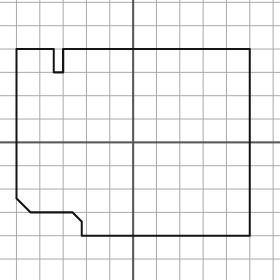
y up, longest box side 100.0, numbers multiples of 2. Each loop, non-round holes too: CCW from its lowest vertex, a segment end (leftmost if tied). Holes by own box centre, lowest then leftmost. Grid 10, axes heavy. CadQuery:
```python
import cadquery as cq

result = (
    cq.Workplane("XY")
    .moveTo(-22.0, -40.0)
    .lineTo(50.0, -40.0)
    .lineTo(50.0, 40.0)
    .lineTo(-30.0, 40.0)
    .lineTo(-30.0, 30.0)
    .lineTo(-34.0, 30.0)
    .lineTo(-34.0, 40.0)
    .lineTo(-50.0, 40.0)
    .lineTo(-50.0, -24.0)
    .lineTo(-44.0, -30.0)
    .lineTo(-26.0, -30.0)
    .lineTo(-22.0, -34.0)
    .close()
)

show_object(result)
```